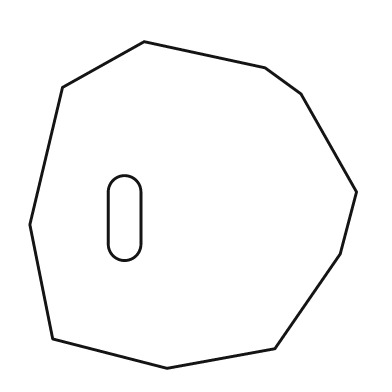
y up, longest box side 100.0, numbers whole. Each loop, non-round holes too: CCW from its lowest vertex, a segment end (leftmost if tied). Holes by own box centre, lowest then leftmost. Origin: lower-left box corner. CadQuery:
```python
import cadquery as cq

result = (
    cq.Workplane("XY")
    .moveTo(42.0, 0.0)
    .lineTo(75.0, 6.0)
    .lineTo(95.0, 35.0)
    .lineTo(100.0, 54.0)
    .lineTo(83.0, 84.0)
    .lineTo(72.0, 92.0)
    .lineTo(35.0, 100.0)
    .lineTo(10.0, 86.0)
    .lineTo(0.0, 44.0)
    .lineTo(7.0, 9.0)
    .close()
    .moveTo(24.0, 38.0)
    .threePointArc((29.0, 33.0), (34.0, 38.0))
    .lineTo(34.0, 54.0)
    .threePointArc((29.0, 59.0), (24.0, 54.0))
    .close()
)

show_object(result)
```